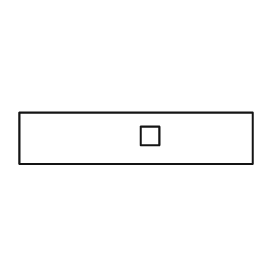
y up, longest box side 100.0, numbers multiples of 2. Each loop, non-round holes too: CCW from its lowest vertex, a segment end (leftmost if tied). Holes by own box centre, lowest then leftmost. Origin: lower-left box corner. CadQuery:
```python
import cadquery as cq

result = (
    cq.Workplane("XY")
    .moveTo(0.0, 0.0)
    .lineTo(100.0, 0.0)
    .lineTo(100.0, 22.0)
    .lineTo(0.0, 22.0)
    .close()
    .moveTo(52.0, 8.0)
    .lineTo(60.0, 8.0)
    .lineTo(60.0, 16.0)
    .lineTo(52.0, 16.0)
    .close()
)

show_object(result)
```